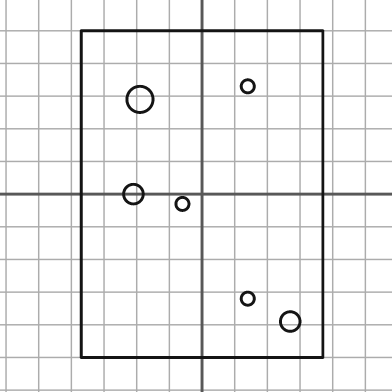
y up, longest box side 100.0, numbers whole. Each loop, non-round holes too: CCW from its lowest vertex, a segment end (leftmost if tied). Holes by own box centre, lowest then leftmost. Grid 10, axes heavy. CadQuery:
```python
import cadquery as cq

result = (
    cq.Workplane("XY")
    .moveTo(-37.0, -50.0)
    .lineTo(37.0, -50.0)
    .lineTo(37.0, 50.0)
    .lineTo(-37.0, 50.0)
    .close()
    .moveTo(27.0, -39.0)
    .circle(3.0)
    .moveTo(14.0, -32.0)
    .circle(2.0)
    .moveTo(-6.0, -3.0)
    .circle(2.0)
    .moveTo(-21.0, 0.0)
    .circle(3.0)
    .moveTo(-19.0, 29.0)
    .circle(4.0)
    .moveTo(14.0, 33.0)
    .circle(2.0)
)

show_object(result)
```